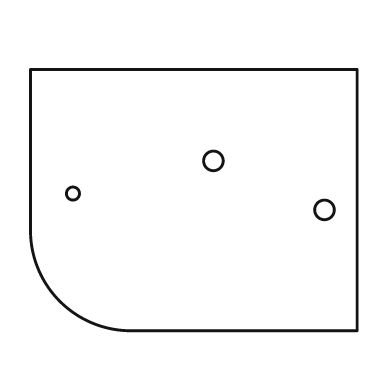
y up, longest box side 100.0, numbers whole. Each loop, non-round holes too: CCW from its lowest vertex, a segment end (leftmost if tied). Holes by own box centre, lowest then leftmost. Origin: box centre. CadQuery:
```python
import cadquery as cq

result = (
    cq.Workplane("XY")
    .moveTo(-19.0, -40.0)
    .lineTo(50.0, -40.0)
    .lineTo(50.0, 40.0)
    .lineTo(-50.0, 40.0)
    .lineTo(-50.0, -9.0)
    .threePointArc((-41.0, -31.0), (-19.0, -40.0))
    .close()
    .moveTo(40.0, -3.0)
    .circle(3.0)
    .moveTo(-37.0, 2.0)
    .circle(2.0)
    .moveTo(6.0, 12.0)
    .circle(3.0)
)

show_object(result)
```